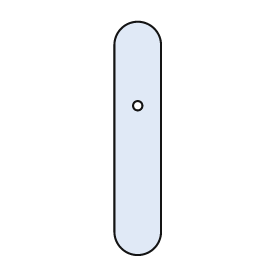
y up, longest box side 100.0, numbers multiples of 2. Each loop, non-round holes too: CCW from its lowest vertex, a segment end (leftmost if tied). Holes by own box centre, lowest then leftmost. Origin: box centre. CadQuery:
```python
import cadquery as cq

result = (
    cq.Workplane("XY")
    .moveTo(-10.0, -40.0)
    .threePointArc((0.0, -50.0), (10.0, -40.0))
    .lineTo(10.0, 40.0)
    .threePointArc((0.0, 50.0), (-10.0, 40.0))
    .close()
    .moveTo(0.0, 14.0)
    .circle(2.0)
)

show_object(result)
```